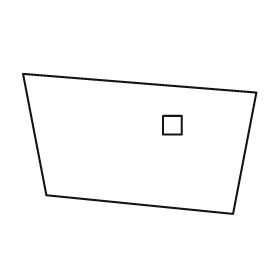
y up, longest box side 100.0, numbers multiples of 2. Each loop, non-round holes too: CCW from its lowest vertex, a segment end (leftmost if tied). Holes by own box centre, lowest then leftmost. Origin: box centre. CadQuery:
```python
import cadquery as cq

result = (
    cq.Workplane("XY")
    .moveTo(40.0, -30.0)
    .lineTo(50.0, 22.0)
    .lineTo(-50.0, 30.0)
    .lineTo(-40.0, -22.0)
    .close()
    .moveTo(10.0, 4.0)
    .lineTo(18.0, 4.0)
    .lineTo(18.0, 12.0)
    .lineTo(10.0, 12.0)
    .close()
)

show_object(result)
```